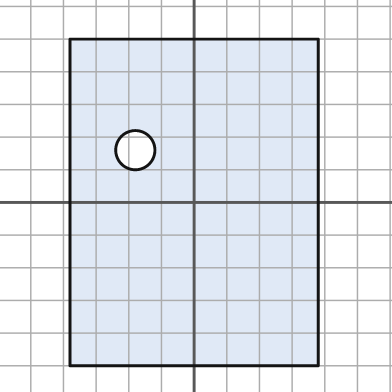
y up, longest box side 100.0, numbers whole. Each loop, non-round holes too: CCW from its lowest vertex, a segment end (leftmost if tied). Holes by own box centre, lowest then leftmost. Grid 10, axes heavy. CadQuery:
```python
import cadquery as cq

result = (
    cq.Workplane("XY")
    .moveTo(-38.0, -50.0)
    .lineTo(38.0, -50.0)
    .lineTo(38.0, 50.0)
    .lineTo(-38.0, 50.0)
    .close()
    .moveTo(-18.0, 16.0)
    .circle(6.0)
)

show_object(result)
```